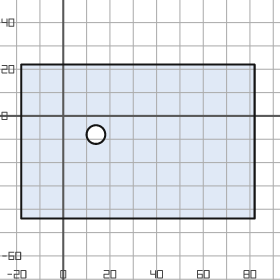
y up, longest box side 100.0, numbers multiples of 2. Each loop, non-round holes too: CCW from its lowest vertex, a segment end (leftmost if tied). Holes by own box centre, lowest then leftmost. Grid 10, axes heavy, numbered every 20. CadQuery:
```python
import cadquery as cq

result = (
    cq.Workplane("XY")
    .moveTo(-18.0, -44.0)
    .lineTo(82.0, -44.0)
    .lineTo(82.0, 22.0)
    .lineTo(-18.0, 22.0)
    .close()
    .moveTo(14.0, -8.0)
    .circle(4.0)
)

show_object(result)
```